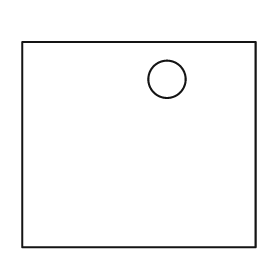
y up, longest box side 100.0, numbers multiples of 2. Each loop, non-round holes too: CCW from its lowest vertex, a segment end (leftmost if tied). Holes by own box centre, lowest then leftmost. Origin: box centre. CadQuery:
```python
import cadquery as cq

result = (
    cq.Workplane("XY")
    .moveTo(-50.0, -44.0)
    .lineTo(50.0, -44.0)
    .lineTo(50.0, 44.0)
    .lineTo(-50.0, 44.0)
    .close()
    .moveTo(12.0, 28.0)
    .circle(8.0)
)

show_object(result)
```